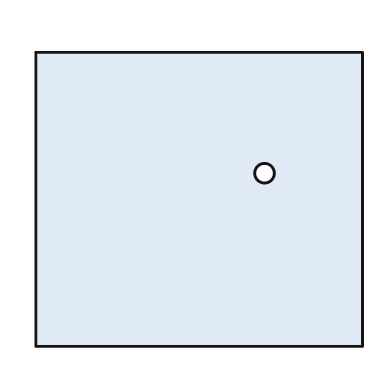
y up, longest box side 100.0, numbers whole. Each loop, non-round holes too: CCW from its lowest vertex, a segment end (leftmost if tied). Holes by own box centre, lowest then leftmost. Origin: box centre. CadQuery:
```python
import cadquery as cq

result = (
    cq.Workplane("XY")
    .moveTo(-50.0, -45.0)
    .lineTo(50.0, -45.0)
    .lineTo(50.0, 45.0)
    .lineTo(-50.0, 45.0)
    .close()
    .moveTo(20.0, 8.0)
    .circle(3.0)
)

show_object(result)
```